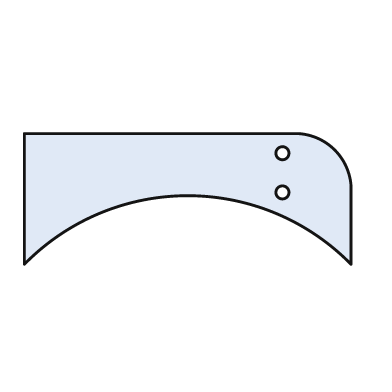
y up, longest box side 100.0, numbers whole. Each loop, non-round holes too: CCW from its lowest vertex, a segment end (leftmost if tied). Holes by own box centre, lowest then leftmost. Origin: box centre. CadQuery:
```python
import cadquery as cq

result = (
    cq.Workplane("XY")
    .moveTo(-50.0, -20.0)
    .threePointArc((0.0, 1.0), (50.0, -20.0))
    .lineTo(50.0, 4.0)
    .threePointArc((45.0, 15.0), (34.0, 20.0))
    .lineTo(-50.0, 20.0)
    .close()
    .moveTo(29.0, 2.0)
    .circle(2.0)
    .moveTo(29.0, 14.0)
    .circle(2.0)
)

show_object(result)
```